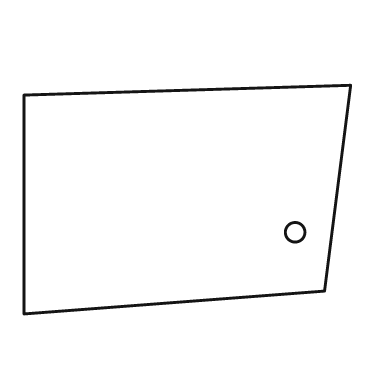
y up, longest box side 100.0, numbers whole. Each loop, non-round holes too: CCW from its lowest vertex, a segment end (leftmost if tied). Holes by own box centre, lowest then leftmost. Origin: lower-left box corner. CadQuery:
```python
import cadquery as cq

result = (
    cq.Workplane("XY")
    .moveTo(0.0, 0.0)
    .lineTo(92.0, 7.0)
    .lineTo(100.0, 70.0)
    .lineTo(0.0, 67.0)
    .close()
    .moveTo(83.0, 25.0)
    .circle(3.0)
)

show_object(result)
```